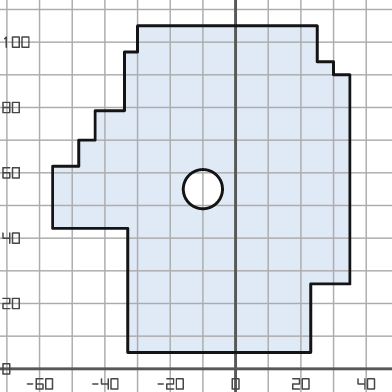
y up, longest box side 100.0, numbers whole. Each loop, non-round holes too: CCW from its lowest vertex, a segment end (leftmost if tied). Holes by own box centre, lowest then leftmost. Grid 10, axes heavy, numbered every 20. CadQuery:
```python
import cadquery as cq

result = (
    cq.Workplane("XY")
    .moveTo(-33.0, 5.0)
    .lineTo(23.0, 5.0)
    .lineTo(23.0, 26.0)
    .lineTo(35.0, 26.0)
    .lineTo(35.0, 90.0)
    .lineTo(30.0, 90.0)
    .lineTo(30.0, 94.0)
    .lineTo(25.0, 94.0)
    .lineTo(25.0, 105.0)
    .lineTo(-30.0, 105.0)
    .lineTo(-30.0, 97.0)
    .lineTo(-34.0, 97.0)
    .lineTo(-34.0, 79.0)
    .lineTo(-43.0, 79.0)
    .lineTo(-43.0, 70.0)
    .lineTo(-48.0, 70.0)
    .lineTo(-48.0, 62.0)
    .lineTo(-56.0, 62.0)
    .lineTo(-56.0, 43.0)
    .lineTo(-33.0, 43.0)
    .close()
    .moveTo(-10.0, 55.0)
    .circle(6.0)
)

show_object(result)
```